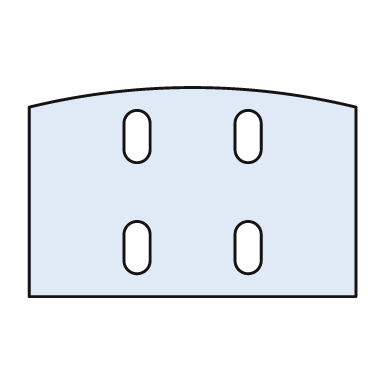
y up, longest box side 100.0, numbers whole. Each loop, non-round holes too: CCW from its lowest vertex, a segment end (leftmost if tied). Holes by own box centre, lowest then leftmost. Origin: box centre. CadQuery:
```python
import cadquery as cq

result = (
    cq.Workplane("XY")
    .moveTo(-50.0, -32.0)
    .lineTo(50.0, -32.0)
    .lineTo(50.0, 26.0)
    .threePointArc((0.0, 32.0), (-50.0, 26.0))
    .close()
    .moveTo(-21.0, -21.0)
    .threePointArc((-17.0, -25.0), (-13.0, -21.0))
    .lineTo(-13.0, -13.0)
    .threePointArc((-17.0, -9.0), (-21.0, -13.0))
    .close()
    .moveTo(13.0, -21.0)
    .threePointArc((17.0, -25.0), (21.0, -21.0))
    .lineTo(21.0, -13.0)
    .threePointArc((17.0, -9.0), (13.0, -13.0))
    .close()
    .moveTo(-21.0, 13.0)
    .threePointArc((-17.0, 9.0), (-13.0, 13.0))
    .lineTo(-13.0, 21.0)
    .threePointArc((-17.0, 25.0), (-21.0, 21.0))
    .close()
    .moveTo(13.0, 13.0)
    .threePointArc((17.0, 9.0), (21.0, 13.0))
    .lineTo(21.0, 21.0)
    .threePointArc((17.0, 25.0), (13.0, 21.0))
    .close()
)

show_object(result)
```